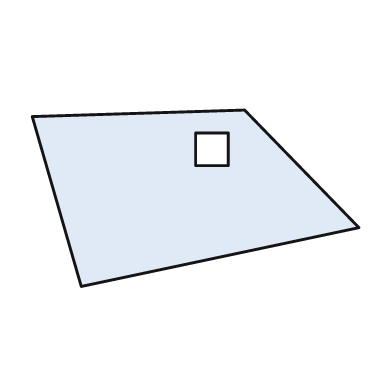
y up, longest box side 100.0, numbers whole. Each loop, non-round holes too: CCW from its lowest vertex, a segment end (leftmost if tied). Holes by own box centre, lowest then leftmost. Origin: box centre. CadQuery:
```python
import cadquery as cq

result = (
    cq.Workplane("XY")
    .moveTo(-35.0, -27.0)
    .lineTo(50.0, -9.0)
    .lineTo(15.0, 27.0)
    .lineTo(-50.0, 25.0)
    .close()
    .moveTo(0.0, 10.0)
    .lineTo(10.0, 10.0)
    .lineTo(10.0, 20.0)
    .lineTo(0.0, 20.0)
    .close()
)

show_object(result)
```